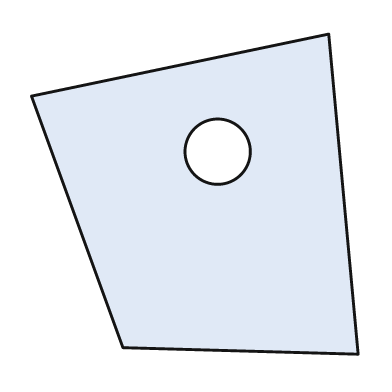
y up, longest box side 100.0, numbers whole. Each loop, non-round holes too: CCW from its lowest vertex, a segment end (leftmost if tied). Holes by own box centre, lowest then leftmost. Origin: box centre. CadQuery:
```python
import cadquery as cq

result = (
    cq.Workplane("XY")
    .moveTo(50.0, -49.0)
    .lineTo(41.0, 49.0)
    .lineTo(-50.0, 30.0)
    .lineTo(-22.0, -47.0)
    .close()
    .moveTo(7.0, 13.0)
    .circle(10.0)
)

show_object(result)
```